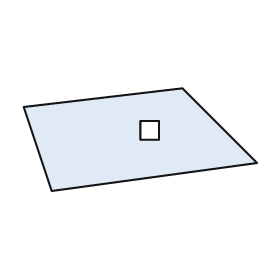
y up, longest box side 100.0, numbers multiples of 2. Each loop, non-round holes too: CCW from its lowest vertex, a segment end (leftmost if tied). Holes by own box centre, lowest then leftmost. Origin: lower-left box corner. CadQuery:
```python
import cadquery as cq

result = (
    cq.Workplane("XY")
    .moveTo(12.0, 0.0)
    .lineTo(100.0, 12.0)
    .lineTo(68.0, 44.0)
    .lineTo(0.0, 36.0)
    .close()
    .moveTo(50.0, 22.0)
    .lineTo(58.0, 22.0)
    .lineTo(58.0, 30.0)
    .lineTo(50.0, 30.0)
    .close()
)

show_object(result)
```